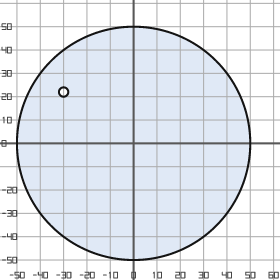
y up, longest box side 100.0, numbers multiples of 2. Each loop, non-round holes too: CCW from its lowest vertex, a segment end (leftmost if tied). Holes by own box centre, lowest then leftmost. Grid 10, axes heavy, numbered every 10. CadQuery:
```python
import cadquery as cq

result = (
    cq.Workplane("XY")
    .moveTo(0.0, 0.0)
    .circle(50.0)
    .moveTo(-30.0, 22.0)
    .circle(2.0)
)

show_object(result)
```